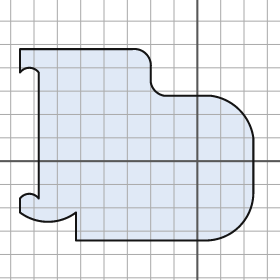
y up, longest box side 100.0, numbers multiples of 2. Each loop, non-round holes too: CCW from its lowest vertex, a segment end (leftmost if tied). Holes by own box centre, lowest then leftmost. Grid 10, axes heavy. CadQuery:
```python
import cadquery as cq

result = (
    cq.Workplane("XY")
    .moveTo(-52.0, -34.0)
    .lineTo(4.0, -34.0)
    .threePointArc((18.0, -28.0), (24.0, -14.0))
    .lineTo(24.0, 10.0)
    .threePointArc((18.0, 22.0), (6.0, 28.0))
    .lineTo(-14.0, 28.0)
    .threePointArc((-18.0, 30.0), (-20.0, 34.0))
    .lineTo(-20.0, 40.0)
    .threePointArc((-22.0, 46.0), (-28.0, 48.0))
    .lineTo(-76.0, 48.0)
    .lineTo(-76.0, 38.0)
    .threePointArc((-72.0, 40.0), (-68.0, 38.0))
    .lineTo(-68.0, -16.0)
    .threePointArc((-72.0, -14.0), (-76.0, -16.0))
    .lineTo(-76.0, -22.0)
    .threePointArc((-64.0, -26.0), (-52.0, -22.0))
    .close()
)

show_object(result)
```